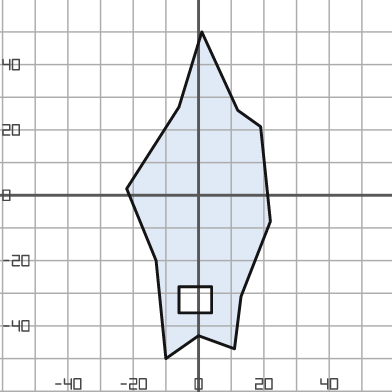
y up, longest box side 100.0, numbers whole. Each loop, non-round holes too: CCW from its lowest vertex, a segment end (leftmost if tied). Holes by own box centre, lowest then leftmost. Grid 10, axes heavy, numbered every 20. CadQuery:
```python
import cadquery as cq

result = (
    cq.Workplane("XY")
    .moveTo(-10.0, -50.0)
    .lineTo(0.0, -43.0)
    .lineTo(11.0, -47.0)
    .lineTo(13.0, -31.0)
    .lineTo(22.0, -8.0)
    .lineTo(19.0, 21.0)
    .lineTo(12.0, 26.0)
    .lineTo(1.0, 50.0)
    .lineTo(-6.0, 27.0)
    .lineTo(-22.0, 2.0)
    .lineTo(-13.0, -20.0)
    .close()
    .moveTo(-6.0, -36.0)
    .lineTo(4.0, -36.0)
    .lineTo(4.0, -28.0)
    .lineTo(-6.0, -28.0)
    .close()
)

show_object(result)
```